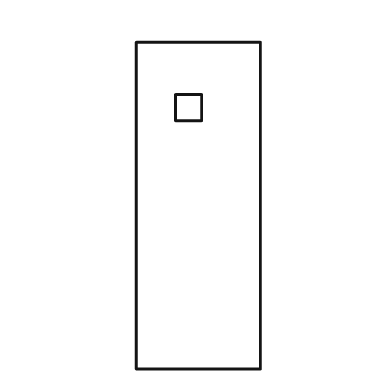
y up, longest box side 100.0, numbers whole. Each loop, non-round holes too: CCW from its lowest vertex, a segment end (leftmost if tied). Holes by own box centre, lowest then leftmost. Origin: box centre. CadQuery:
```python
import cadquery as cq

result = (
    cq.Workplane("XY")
    .moveTo(-19.0, -50.0)
    .lineTo(19.0, -50.0)
    .lineTo(19.0, 50.0)
    .lineTo(-19.0, 50.0)
    .close()
    .moveTo(-7.0, 26.0)
    .lineTo(1.0, 26.0)
    .lineTo(1.0, 34.0)
    .lineTo(-7.0, 34.0)
    .close()
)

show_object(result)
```